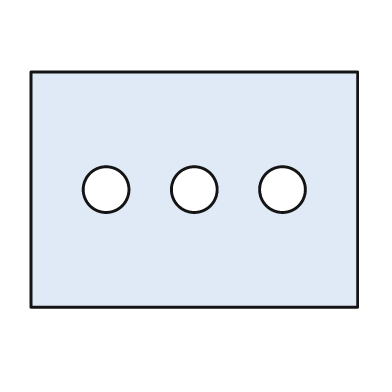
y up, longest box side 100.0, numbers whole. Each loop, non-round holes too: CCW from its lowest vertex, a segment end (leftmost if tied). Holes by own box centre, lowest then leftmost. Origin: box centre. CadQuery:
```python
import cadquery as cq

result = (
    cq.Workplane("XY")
    .moveTo(-50.0, -36.0)
    .lineTo(50.0, -36.0)
    .lineTo(50.0, 36.0)
    .lineTo(-50.0, 36.0)
    .close()
    .moveTo(-27.0, 0.0)
    .circle(7.0)
    .moveTo(0.0, 0.0)
    .circle(7.0)
    .moveTo(27.0, 0.0)
    .circle(7.0)
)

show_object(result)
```